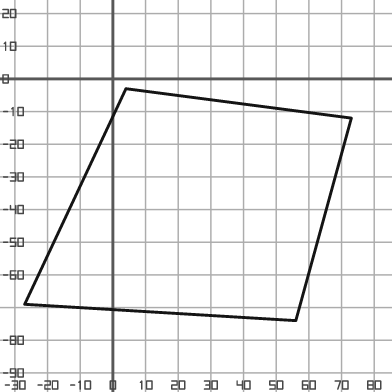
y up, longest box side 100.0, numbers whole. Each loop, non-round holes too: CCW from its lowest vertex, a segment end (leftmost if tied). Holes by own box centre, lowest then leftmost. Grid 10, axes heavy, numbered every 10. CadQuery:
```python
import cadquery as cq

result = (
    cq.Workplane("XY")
    .moveTo(56.0, -74.0)
    .lineTo(73.0, -12.0)
    .lineTo(4.0, -3.0)
    .lineTo(-27.0, -69.0)
    .close()
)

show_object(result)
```